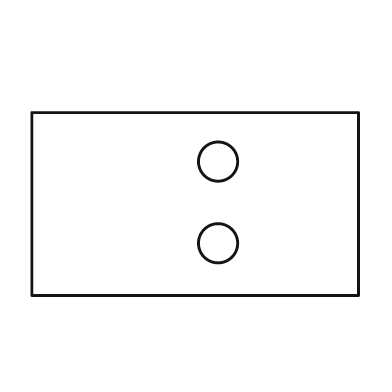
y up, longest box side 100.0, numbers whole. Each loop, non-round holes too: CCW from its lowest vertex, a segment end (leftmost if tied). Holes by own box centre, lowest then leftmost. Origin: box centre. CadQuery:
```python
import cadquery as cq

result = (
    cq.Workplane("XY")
    .moveTo(-50.0, -28.0)
    .lineTo(50.0, -28.0)
    .lineTo(50.0, 28.0)
    .lineTo(-50.0, 28.0)
    .close()
    .moveTo(7.0, -12.0)
    .circle(6.0)
    .moveTo(7.0, 13.0)
    .circle(6.0)
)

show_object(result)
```